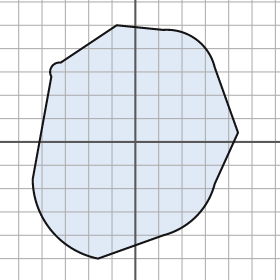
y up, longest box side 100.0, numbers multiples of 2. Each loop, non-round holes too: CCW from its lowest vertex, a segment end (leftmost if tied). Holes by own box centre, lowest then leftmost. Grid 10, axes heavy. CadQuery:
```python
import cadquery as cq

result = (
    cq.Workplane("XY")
    .moveTo(-16.0, -50.0)
    .lineTo(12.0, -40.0)
    .threePointArc((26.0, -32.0), (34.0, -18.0))
    .lineTo(44.0, 4.0)
    .lineTo(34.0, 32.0)
    .threePointArc((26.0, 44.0), (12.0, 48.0))
    .lineTo(-8.0, 50.0)
    .lineTo(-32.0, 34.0)
    .threePointArc((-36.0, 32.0), (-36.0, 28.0))
    .lineTo(-44.0, -16.0)
    .threePointArc((-36.0, -38.0), (-16.0, -50.0))
    .close()
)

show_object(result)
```